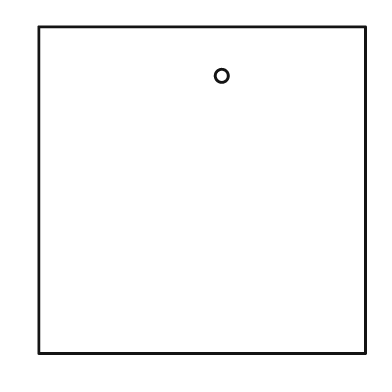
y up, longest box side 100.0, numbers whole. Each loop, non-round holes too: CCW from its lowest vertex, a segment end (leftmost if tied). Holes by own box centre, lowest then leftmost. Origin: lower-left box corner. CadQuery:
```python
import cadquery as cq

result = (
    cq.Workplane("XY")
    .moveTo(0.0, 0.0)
    .lineTo(100.0, 0.0)
    .lineTo(100.0, 100.0)
    .lineTo(0.0, 100.0)
    .close()
    .moveTo(56.0, 85.0)
    .circle(2.0)
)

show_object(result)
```